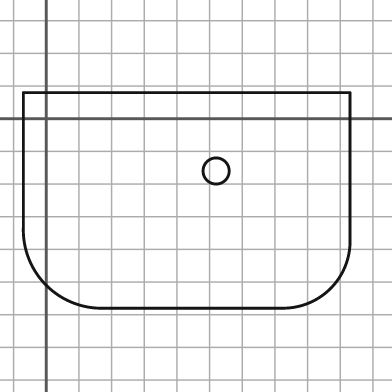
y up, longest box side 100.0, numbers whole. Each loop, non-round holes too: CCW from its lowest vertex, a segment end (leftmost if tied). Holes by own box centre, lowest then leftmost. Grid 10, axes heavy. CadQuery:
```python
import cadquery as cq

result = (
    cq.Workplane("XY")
    .moveTo(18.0, -58.0)
    .lineTo(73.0, -58.0)
    .threePointArc((87.0, -52.0), (93.0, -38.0))
    .lineTo(93.0, 8.0)
    .lineTo(-7.0, 8.0)
    .lineTo(-7.0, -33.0)
    .threePointArc((0.0, -51.0), (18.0, -58.0))
    .close()
    .moveTo(52.0, -16.0)
    .circle(4.0)
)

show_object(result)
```